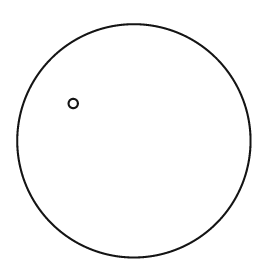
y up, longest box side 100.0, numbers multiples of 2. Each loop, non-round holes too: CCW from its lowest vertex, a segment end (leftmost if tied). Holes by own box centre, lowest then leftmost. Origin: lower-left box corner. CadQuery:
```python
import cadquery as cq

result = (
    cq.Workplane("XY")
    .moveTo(50.0, 50.0)
    .circle(50.0)
    .moveTo(24.0, 66.0)
    .circle(2.0)
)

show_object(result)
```